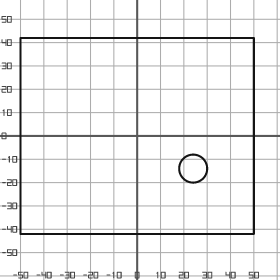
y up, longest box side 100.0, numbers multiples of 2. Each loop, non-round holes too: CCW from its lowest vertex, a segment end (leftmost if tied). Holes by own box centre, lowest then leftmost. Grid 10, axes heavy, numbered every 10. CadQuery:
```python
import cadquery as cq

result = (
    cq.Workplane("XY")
    .moveTo(-50.0, -42.0)
    .lineTo(50.0, -42.0)
    .lineTo(50.0, 42.0)
    .lineTo(-50.0, 42.0)
    .close()
    .moveTo(24.0, -14.0)
    .circle(6.0)
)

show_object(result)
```